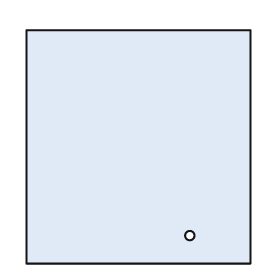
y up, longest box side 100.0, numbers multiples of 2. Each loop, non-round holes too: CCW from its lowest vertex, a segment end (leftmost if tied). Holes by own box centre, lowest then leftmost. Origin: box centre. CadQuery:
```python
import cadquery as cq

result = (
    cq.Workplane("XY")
    .moveTo(-48.0, -50.0)
    .lineTo(48.0, -50.0)
    .lineTo(48.0, 50.0)
    .lineTo(-48.0, 50.0)
    .close()
    .moveTo(22.0, -38.0)
    .circle(2.0)
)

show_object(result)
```